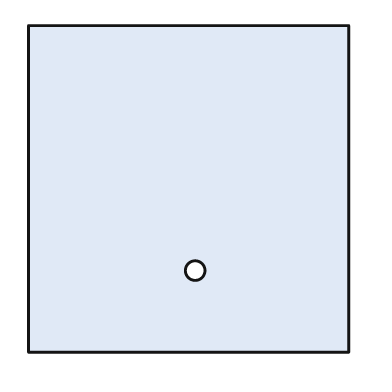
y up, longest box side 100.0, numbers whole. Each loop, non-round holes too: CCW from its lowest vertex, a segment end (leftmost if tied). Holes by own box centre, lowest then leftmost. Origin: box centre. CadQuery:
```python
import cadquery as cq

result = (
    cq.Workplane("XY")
    .moveTo(-49.0, -50.0)
    .lineTo(49.0, -50.0)
    .lineTo(49.0, 50.0)
    .lineTo(-49.0, 50.0)
    .close()
    .moveTo(2.0, -25.0)
    .circle(3.0)
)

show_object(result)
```